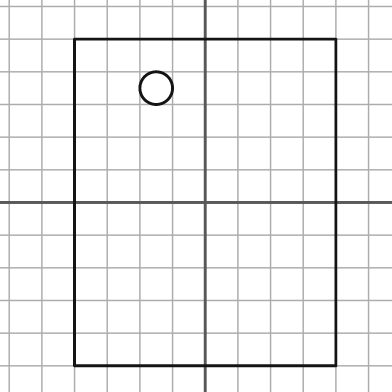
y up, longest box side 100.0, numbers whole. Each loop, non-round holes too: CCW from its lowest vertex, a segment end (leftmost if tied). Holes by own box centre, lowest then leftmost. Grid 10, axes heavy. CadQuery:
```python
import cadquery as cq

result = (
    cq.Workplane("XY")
    .moveTo(-40.0, -50.0)
    .lineTo(40.0, -50.0)
    .lineTo(40.0, 50.0)
    .lineTo(-40.0, 50.0)
    .close()
    .moveTo(-15.0, 35.0)
    .circle(5.0)
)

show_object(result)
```